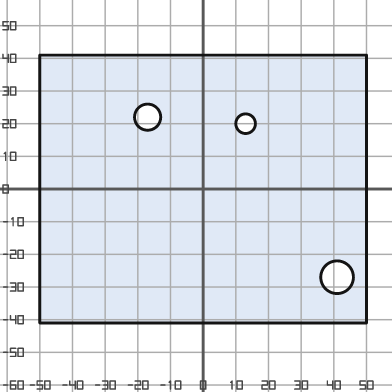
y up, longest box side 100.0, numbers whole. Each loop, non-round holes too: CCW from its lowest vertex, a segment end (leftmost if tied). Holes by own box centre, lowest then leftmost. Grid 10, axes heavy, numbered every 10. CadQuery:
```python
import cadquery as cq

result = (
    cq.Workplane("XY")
    .moveTo(-50.0, -41.0)
    .lineTo(50.0, -41.0)
    .lineTo(50.0, 41.0)
    .lineTo(-50.0, 41.0)
    .close()
    .moveTo(41.0, -27.0)
    .circle(5.0)
    .moveTo(13.0, 20.0)
    .circle(3.0)
    .moveTo(-17.0, 22.0)
    .circle(4.0)
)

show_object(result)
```